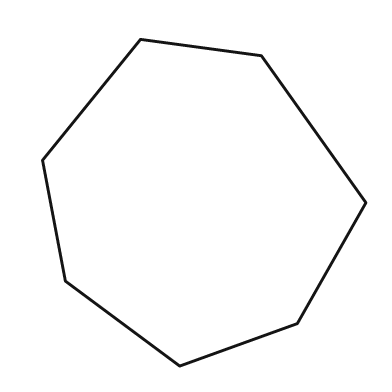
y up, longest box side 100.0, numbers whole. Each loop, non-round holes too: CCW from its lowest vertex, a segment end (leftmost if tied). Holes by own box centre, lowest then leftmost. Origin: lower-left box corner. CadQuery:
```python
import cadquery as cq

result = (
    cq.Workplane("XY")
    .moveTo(42.0, 0.0)
    .lineTo(78.0, 13.0)
    .lineTo(99.0, 50.0)
    .lineTo(67.0, 95.0)
    .lineTo(30.0, 100.0)
    .lineTo(0.0, 63.0)
    .lineTo(7.0, 26.0)
    .close()
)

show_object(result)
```